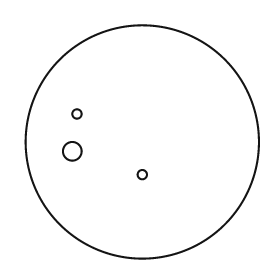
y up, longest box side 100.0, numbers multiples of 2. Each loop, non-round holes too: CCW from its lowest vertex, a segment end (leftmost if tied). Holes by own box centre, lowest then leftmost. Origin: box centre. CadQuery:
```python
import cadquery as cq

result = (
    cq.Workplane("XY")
    .moveTo(0.0, 0.0)
    .circle(50.0)
    .moveTo(0.0, -14.0)
    .circle(2.0)
    .moveTo(-30.0, -4.0)
    .circle(4.0)
    .moveTo(-28.0, 12.0)
    .circle(2.0)
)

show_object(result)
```